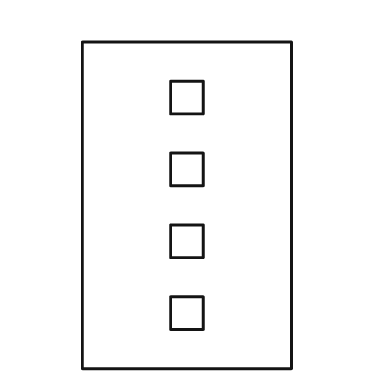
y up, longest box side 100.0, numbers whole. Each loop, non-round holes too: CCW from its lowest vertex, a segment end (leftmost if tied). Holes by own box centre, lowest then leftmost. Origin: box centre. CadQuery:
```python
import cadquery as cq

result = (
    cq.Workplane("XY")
    .moveTo(-32.0, -50.0)
    .lineTo(32.0, -50.0)
    .lineTo(32.0, 50.0)
    .lineTo(-32.0, 50.0)
    .close()
    .moveTo(-5.0, -38.0)
    .lineTo(5.0, -38.0)
    .lineTo(5.0, -28.0)
    .lineTo(-5.0, -28.0)
    .close()
    .moveTo(-5.0, -16.0)
    .lineTo(5.0, -16.0)
    .lineTo(5.0, -6.0)
    .lineTo(-5.0, -6.0)
    .close()
    .moveTo(-5.0, 6.0)
    .lineTo(5.0, 6.0)
    .lineTo(5.0, 16.0)
    .lineTo(-5.0, 16.0)
    .close()
    .moveTo(-5.0, 28.0)
    .lineTo(5.0, 28.0)
    .lineTo(5.0, 38.0)
    .lineTo(-5.0, 38.0)
    .close()
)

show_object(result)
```